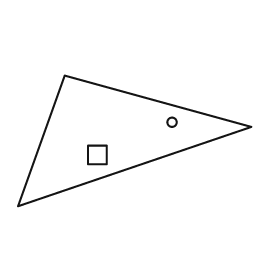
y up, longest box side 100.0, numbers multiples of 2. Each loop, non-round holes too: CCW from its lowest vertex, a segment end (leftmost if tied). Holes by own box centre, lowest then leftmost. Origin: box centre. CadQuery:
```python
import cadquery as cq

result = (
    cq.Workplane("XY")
    .moveTo(-50.0, -28.0)
    .lineTo(50.0, 6.0)
    .lineTo(-30.0, 28.0)
    .close()
    .moveTo(-20.0, -10.0)
    .lineTo(-12.0, -10.0)
    .lineTo(-12.0, -2.0)
    .lineTo(-20.0, -2.0)
    .close()
    .moveTo(16.0, 8.0)
    .circle(2.0)
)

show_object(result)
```